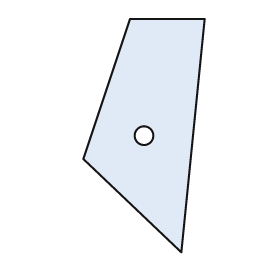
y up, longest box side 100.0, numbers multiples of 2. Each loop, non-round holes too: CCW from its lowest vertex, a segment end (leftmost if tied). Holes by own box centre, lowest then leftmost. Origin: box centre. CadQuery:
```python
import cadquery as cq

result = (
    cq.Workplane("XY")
    .moveTo(16.0, -50.0)
    .lineTo(26.0, 50.0)
    .lineTo(-6.0, 50.0)
    .lineTo(-26.0, -10.0)
    .close()
    .moveTo(0.0, 0.0)
    .circle(4.0)
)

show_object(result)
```